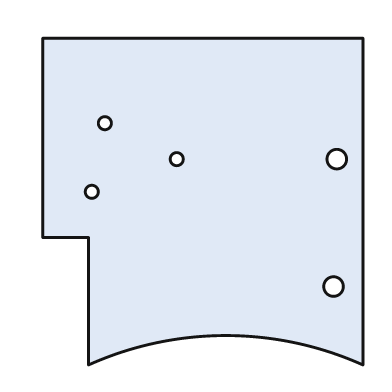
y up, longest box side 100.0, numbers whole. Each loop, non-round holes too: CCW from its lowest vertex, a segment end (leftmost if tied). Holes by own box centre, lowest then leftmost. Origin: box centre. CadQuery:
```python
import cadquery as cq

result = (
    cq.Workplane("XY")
    .moveTo(-35.0, -50.0)
    .threePointArc((7.0, -41.0), (49.0, -50.0))
    .lineTo(49.0, 50.0)
    .lineTo(-49.0, 50.0)
    .lineTo(-49.0, -11.0)
    .lineTo(-35.0, -11.0)
    .close()
    .moveTo(40.0, -26.0)
    .circle(3.0)
    .moveTo(-34.0, 3.0)
    .circle(2.0)
    .moveTo(-8.0, 13.0)
    .circle(2.0)
    .moveTo(41.0, 13.0)
    .circle(3.0)
    .moveTo(-30.0, 24.0)
    .circle(2.0)
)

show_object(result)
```